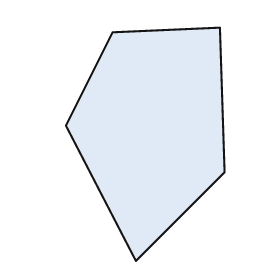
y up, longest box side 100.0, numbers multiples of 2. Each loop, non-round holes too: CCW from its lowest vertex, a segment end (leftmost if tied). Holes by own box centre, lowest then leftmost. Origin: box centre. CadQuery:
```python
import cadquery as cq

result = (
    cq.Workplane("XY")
    .moveTo(-4.0, -50.0)
    .lineTo(34.0, -12.0)
    .lineTo(32.0, 50.0)
    .lineTo(-14.0, 48.0)
    .lineTo(-34.0, 8.0)
    .close()
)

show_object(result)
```